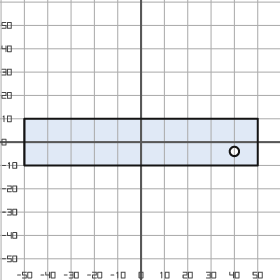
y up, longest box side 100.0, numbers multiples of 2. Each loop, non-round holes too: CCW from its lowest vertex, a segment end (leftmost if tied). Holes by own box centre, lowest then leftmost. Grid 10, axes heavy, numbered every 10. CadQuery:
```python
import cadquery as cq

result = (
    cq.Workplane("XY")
    .moveTo(-50.0, -10.0)
    .lineTo(50.0, -10.0)
    .lineTo(50.0, 10.0)
    .lineTo(-50.0, 10.0)
    .close()
    .moveTo(40.0, -4.0)
    .circle(2.0)
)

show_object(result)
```